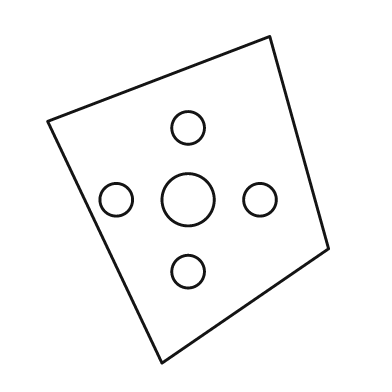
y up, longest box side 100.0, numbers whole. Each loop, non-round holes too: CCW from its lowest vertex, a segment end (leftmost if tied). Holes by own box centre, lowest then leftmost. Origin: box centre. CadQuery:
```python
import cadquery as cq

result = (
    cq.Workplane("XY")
    .moveTo(-8.0, -50.0)
    .lineTo(43.0, -15.0)
    .lineTo(25.0, 50.0)
    .lineTo(-43.0, 24.0)
    .close()
    .moveTo(0.0, -22.0)
    .circle(5.0)
    .moveTo(-22.0, 0.0)
    .circle(5.0)
    .moveTo(0.0, 0.0)
    .circle(8.0)
    .moveTo(22.0, 0.0)
    .circle(5.0)
    .moveTo(0.0, 22.0)
    .circle(5.0)
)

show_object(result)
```